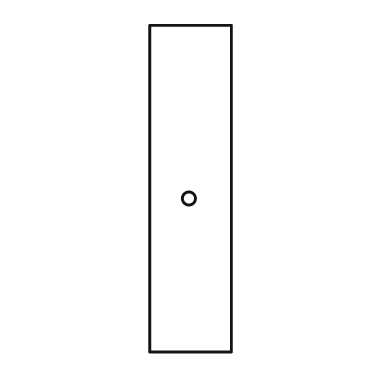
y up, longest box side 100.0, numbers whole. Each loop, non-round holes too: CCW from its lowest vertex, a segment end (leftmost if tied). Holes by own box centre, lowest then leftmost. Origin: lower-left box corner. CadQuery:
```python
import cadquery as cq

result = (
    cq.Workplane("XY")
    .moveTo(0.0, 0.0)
    .lineTo(25.0, 0.0)
    .lineTo(25.0, 100.0)
    .lineTo(0.0, 100.0)
    .close()
    .moveTo(12.0, 47.0)
    .circle(2.0)
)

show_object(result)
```